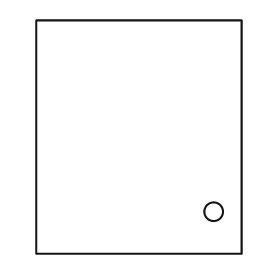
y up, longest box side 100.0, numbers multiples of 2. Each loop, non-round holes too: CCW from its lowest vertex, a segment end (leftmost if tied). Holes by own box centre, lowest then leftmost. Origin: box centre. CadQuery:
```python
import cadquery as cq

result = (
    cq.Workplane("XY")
    .moveTo(-44.0, -50.0)
    .lineTo(44.0, -50.0)
    .lineTo(44.0, 50.0)
    .lineTo(-44.0, 50.0)
    .close()
    .moveTo(32.0, -32.0)
    .circle(4.0)
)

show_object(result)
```